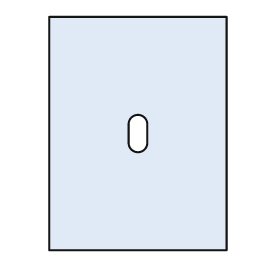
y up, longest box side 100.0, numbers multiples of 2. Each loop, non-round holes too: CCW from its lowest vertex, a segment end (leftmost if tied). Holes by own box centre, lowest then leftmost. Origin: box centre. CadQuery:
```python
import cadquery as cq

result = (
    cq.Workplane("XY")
    .moveTo(-38.0, -50.0)
    .lineTo(38.0, -50.0)
    .lineTo(38.0, 50.0)
    .lineTo(-38.0, 50.0)
    .close()
    .moveTo(-4.0, -4.0)
    .threePointArc((0.0, -8.0), (4.0, -4.0))
    .lineTo(4.0, 4.0)
    .threePointArc((0.0, 8.0), (-4.0, 4.0))
    .close()
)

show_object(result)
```